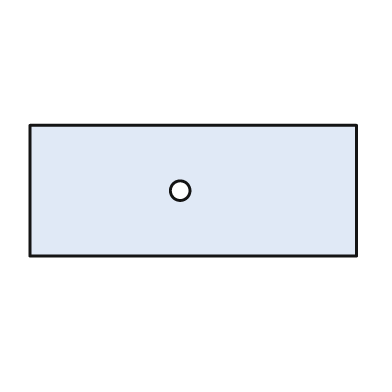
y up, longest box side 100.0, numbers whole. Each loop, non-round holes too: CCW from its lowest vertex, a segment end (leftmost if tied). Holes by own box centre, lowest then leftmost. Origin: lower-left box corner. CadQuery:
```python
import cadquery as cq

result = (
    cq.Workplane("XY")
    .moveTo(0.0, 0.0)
    .lineTo(100.0, 0.0)
    .lineTo(100.0, 40.0)
    .lineTo(0.0, 40.0)
    .close()
    .moveTo(46.0, 20.0)
    .circle(3.0)
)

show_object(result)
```